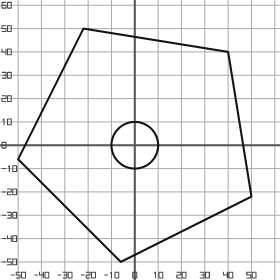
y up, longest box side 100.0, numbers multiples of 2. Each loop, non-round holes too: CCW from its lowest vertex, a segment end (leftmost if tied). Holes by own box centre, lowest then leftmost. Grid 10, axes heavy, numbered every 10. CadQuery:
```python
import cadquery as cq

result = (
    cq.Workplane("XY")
    .moveTo(-6.0, -50.0)
    .lineTo(50.0, -22.0)
    .lineTo(40.0, 40.0)
    .lineTo(-22.0, 50.0)
    .lineTo(-50.0, -6.0)
    .close()
    .moveTo(0.0, 0.0)
    .circle(10.0)
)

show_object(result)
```